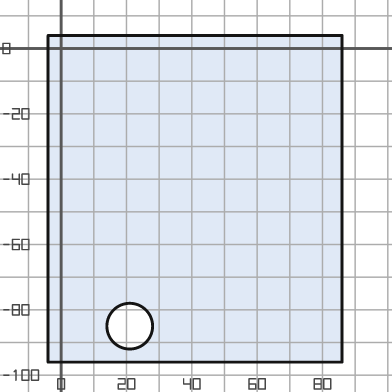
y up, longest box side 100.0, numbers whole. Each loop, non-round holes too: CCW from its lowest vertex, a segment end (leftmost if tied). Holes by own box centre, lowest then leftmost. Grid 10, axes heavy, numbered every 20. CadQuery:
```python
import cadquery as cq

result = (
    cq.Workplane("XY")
    .moveTo(-4.0, -96.0)
    .lineTo(86.0, -96.0)
    .lineTo(86.0, 4.0)
    .lineTo(-4.0, 4.0)
    .close()
    .moveTo(21.0, -85.0)
    .circle(7.0)
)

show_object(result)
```